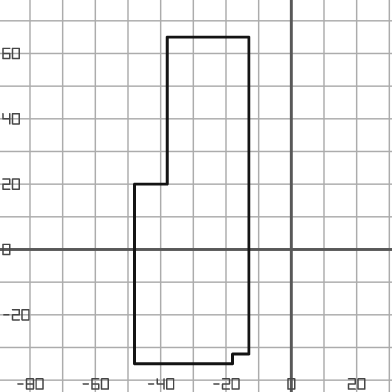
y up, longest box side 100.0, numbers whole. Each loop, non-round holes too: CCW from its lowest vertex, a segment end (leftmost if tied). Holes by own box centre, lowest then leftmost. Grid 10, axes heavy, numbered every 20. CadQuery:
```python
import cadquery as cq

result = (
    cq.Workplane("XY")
    .moveTo(-48.0, -35.0)
    .lineTo(-18.0, -35.0)
    .lineTo(-18.0, -32.0)
    .lineTo(-13.0, -32.0)
    .lineTo(-13.0, 65.0)
    .lineTo(-38.0, 65.0)
    .lineTo(-38.0, 20.0)
    .lineTo(-48.0, 20.0)
    .close()
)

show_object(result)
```